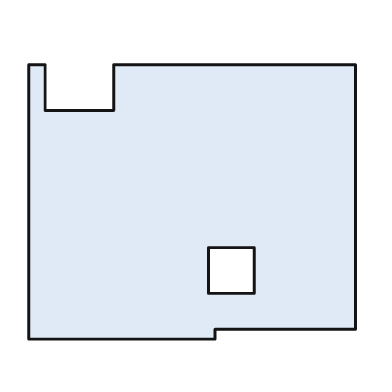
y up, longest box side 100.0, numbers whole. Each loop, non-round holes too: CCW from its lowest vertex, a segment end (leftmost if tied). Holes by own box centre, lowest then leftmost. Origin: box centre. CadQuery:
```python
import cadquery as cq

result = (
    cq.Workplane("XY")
    .moveTo(-50.0, -42.0)
    .lineTo(7.0, -42.0)
    .lineTo(7.0, -39.0)
    .lineTo(50.0, -39.0)
    .lineTo(50.0, 42.0)
    .lineTo(-24.0, 42.0)
    .lineTo(-24.0, 28.0)
    .lineTo(-45.0, 28.0)
    .lineTo(-45.0, 42.0)
    .lineTo(-50.0, 42.0)
    .close()
    .moveTo(5.0, -28.0)
    .lineTo(19.0, -28.0)
    .lineTo(19.0, -14.0)
    .lineTo(5.0, -14.0)
    .close()
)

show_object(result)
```